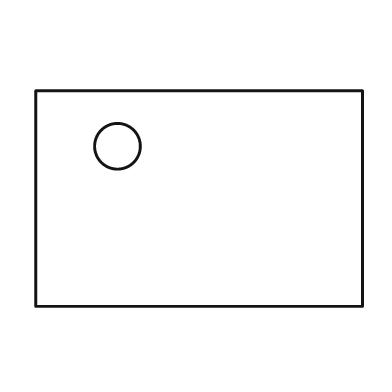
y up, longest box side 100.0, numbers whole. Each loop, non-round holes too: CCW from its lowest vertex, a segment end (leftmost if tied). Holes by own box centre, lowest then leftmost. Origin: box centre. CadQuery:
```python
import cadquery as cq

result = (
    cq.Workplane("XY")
    .moveTo(-50.0, -33.0)
    .lineTo(50.0, -33.0)
    .lineTo(50.0, 33.0)
    .lineTo(-50.0, 33.0)
    .close()
    .moveTo(-25.0, 16.0)
    .circle(7.0)
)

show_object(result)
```